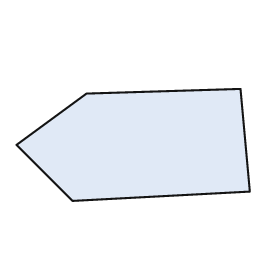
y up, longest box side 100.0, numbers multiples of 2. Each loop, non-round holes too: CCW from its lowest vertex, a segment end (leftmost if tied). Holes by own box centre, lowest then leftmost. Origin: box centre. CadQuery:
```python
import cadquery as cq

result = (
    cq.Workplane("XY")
    .moveTo(-26.0, -24.0)
    .lineTo(50.0, -20.0)
    .lineTo(46.0, 24.0)
    .lineTo(-20.0, 22.0)
    .lineTo(-50.0, 0.0)
    .close()
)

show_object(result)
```